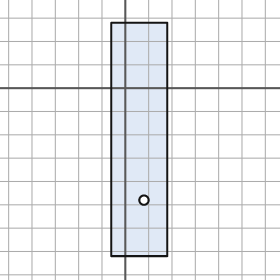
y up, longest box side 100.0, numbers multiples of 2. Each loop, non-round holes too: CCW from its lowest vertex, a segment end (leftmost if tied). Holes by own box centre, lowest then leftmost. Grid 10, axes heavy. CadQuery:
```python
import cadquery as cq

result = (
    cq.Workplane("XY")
    .moveTo(-6.0, -72.0)
    .lineTo(18.0, -72.0)
    .lineTo(18.0, 28.0)
    .lineTo(-6.0, 28.0)
    .close()
    .moveTo(8.0, -48.0)
    .circle(2.0)
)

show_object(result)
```